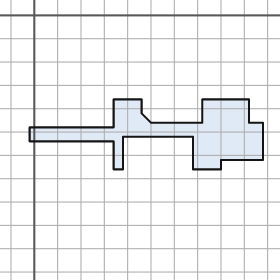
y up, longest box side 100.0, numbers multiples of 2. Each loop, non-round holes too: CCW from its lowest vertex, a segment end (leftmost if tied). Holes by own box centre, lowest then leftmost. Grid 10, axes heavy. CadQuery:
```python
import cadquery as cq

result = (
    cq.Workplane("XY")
    .moveTo(34.0, -66.0)
    .lineTo(38.0, -66.0)
    .lineTo(38.0, -52.0)
    .lineTo(68.0, -52.0)
    .lineTo(68.0, -66.0)
    .lineTo(80.0, -66.0)
    .lineTo(80.0, -62.0)
    .lineTo(98.0, -62.0)
    .lineTo(98.0, -46.0)
    .lineTo(92.0, -46.0)
    .lineTo(92.0, -36.0)
    .lineTo(72.0, -36.0)
    .lineTo(72.0, -46.0)
    .lineTo(50.0, -46.0)
    .lineTo(46.0, -42.0)
    .lineTo(46.0, -36.0)
    .lineTo(34.0, -36.0)
    .lineTo(34.0, -48.0)
    .lineTo(-2.0, -48.0)
    .lineTo(-2.0, -54.0)
    .lineTo(34.0, -54.0)
    .close()
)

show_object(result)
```